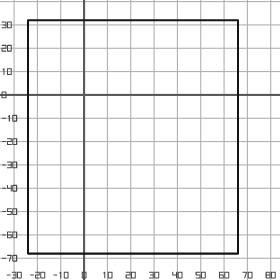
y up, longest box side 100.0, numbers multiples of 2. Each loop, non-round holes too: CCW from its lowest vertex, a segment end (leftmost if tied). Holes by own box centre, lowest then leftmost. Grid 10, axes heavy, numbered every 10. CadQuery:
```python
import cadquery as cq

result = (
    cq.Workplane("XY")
    .moveTo(-24.0, -68.0)
    .lineTo(66.0, -68.0)
    .lineTo(66.0, 32.0)
    .lineTo(-24.0, 32.0)
    .close()
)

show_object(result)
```